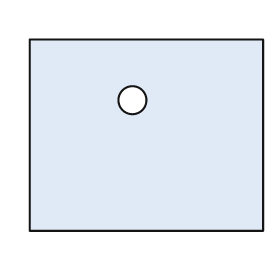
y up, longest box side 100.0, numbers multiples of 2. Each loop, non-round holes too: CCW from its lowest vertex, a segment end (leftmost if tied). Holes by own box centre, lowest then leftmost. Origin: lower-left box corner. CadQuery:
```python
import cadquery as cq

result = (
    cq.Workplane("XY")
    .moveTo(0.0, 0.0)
    .lineTo(100.0, 0.0)
    .lineTo(100.0, 82.0)
    .lineTo(0.0, 82.0)
    .close()
    .moveTo(44.0, 56.0)
    .circle(6.0)
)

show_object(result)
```